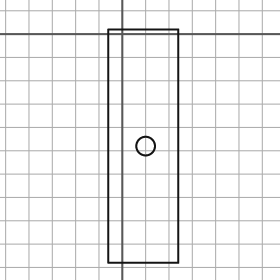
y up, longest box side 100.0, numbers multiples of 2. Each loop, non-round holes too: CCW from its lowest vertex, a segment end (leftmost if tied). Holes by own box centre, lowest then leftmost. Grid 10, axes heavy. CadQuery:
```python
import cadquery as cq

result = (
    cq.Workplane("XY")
    .moveTo(-6.0, -98.0)
    .lineTo(24.0, -98.0)
    .lineTo(24.0, 2.0)
    .lineTo(-6.0, 2.0)
    .close()
    .moveTo(10.0, -48.0)
    .circle(4.0)
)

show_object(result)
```